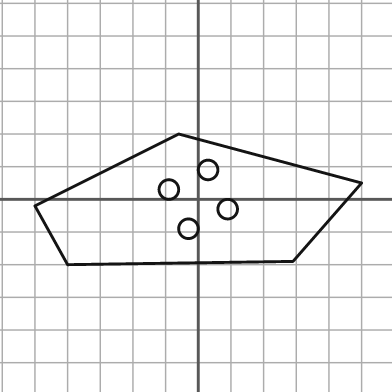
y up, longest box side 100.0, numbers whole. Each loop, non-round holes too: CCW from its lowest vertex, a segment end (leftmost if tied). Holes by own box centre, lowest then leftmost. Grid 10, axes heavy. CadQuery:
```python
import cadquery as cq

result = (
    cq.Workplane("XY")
    .moveTo(-40.0, -20.0)
    .lineTo(29.0, -19.0)
    .lineTo(50.0, 5.0)
    .lineTo(-6.0, 20.0)
    .lineTo(-50.0, -2.0)
    .close()
    .moveTo(-3.0, -9.0)
    .circle(3.0)
    .moveTo(9.0, -3.0)
    .circle(3.0)
    .moveTo(-9.0, 3.0)
    .circle(3.0)
    .moveTo(3.0, 9.0)
    .circle(3.0)
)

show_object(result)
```